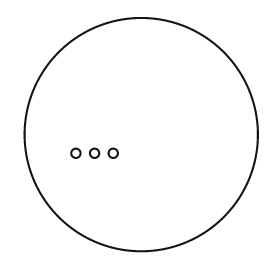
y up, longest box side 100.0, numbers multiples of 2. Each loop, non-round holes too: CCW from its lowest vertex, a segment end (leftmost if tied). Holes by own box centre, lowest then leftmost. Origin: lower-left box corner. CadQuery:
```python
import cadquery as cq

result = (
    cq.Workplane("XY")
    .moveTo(50.0, 50.0)
    .circle(50.0)
    .moveTo(22.0, 42.0)
    .circle(2.0)
    .moveTo(30.0, 42.0)
    .circle(2.0)
    .moveTo(38.0, 42.0)
    .circle(2.0)
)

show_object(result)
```